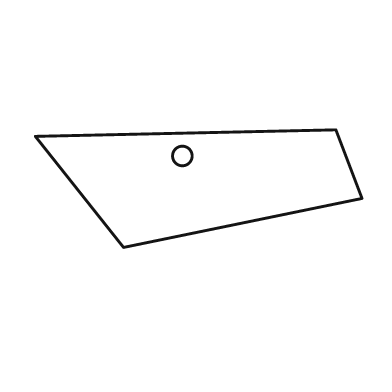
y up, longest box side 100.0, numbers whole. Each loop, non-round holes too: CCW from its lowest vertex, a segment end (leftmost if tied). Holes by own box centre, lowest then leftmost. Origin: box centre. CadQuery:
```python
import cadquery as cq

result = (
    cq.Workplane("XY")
    .moveTo(-23.0, -18.0)
    .lineTo(50.0, -3.0)
    .lineTo(42.0, 18.0)
    .lineTo(-50.0, 16.0)
    .close()
    .moveTo(-5.0, 10.0)
    .circle(3.0)
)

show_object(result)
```